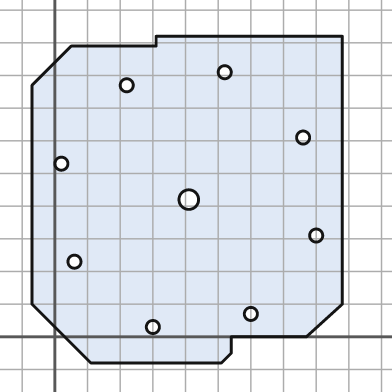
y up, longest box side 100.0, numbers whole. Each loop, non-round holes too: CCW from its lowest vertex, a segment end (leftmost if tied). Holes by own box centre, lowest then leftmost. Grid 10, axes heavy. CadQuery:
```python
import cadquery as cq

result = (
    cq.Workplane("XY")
    .moveTo(11.0, -8.0)
    .lineTo(51.0, -8.0)
    .lineTo(54.0, -5.0)
    .lineTo(54.0, 0.0)
    .lineTo(77.0, 0.0)
    .lineTo(88.0, 10.0)
    .lineTo(88.0, 92.0)
    .lineTo(31.0, 92.0)
    .lineTo(31.0, 89.0)
    .lineTo(5.0, 89.0)
    .lineTo(-7.0, 77.0)
    .lineTo(-7.0, 10.0)
    .close()
    .moveTo(30.0, 3.0)
    .circle(2.0)
    .moveTo(60.0, 7.0)
    .circle(2.0)
    .moveTo(6.0, 23.0)
    .circle(2.0)
    .moveTo(80.0, 31.0)
    .circle(2.0)
    .moveTo(41.0, 42.0)
    .circle(3.0)
    .moveTo(2.0, 53.0)
    .circle(2.0)
    .moveTo(76.0, 61.0)
    .circle(2.0)
    .moveTo(22.0, 77.0)
    .circle(2.0)
    .moveTo(52.0, 81.0)
    .circle(2.0)
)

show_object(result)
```